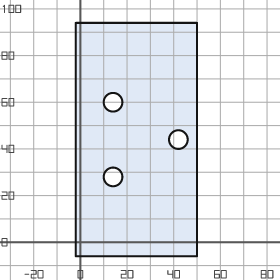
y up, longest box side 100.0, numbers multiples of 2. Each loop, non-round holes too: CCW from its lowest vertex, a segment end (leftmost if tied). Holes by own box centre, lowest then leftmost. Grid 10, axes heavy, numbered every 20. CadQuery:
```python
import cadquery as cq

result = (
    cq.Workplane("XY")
    .moveTo(-2.0, -6.0)
    .lineTo(50.0, -6.0)
    .lineTo(50.0, 94.0)
    .lineTo(-2.0, 94.0)
    .close()
    .moveTo(14.0, 28.0)
    .circle(4.0)
    .moveTo(42.0, 44.0)
    .circle(4.0)
    .moveTo(14.0, 60.0)
    .circle(4.0)
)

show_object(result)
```